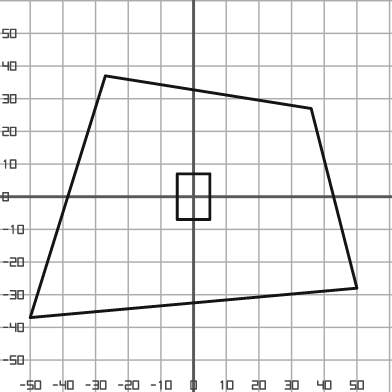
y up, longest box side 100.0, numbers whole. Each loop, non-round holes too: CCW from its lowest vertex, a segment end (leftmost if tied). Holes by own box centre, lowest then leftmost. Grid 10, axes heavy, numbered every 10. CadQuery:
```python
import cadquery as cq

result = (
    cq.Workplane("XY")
    .moveTo(-50.0, -37.0)
    .lineTo(50.0, -28.0)
    .lineTo(36.0, 27.0)
    .lineTo(-27.0, 37.0)
    .close()
    .moveTo(-5.0, -7.0)
    .lineTo(5.0, -7.0)
    .lineTo(5.0, 7.0)
    .lineTo(-5.0, 7.0)
    .close()
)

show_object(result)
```